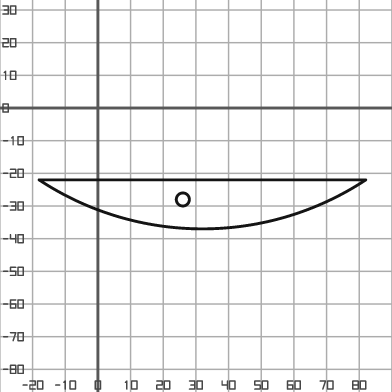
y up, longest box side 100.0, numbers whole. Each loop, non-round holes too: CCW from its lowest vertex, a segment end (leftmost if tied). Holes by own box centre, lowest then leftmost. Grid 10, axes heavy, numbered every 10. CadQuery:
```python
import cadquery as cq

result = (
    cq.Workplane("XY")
    .moveTo(-18.0, -22.0)
    .threePointArc((32.0, -37.0), (82.0, -22.0))
    .close()
    .moveTo(26.0, -28.0)
    .circle(2.0)
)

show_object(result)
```